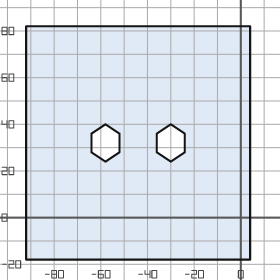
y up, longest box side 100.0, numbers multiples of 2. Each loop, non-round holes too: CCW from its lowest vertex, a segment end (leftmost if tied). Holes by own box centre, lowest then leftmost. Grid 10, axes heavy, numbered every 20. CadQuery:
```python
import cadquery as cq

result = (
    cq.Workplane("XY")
    .moveTo(-92.0, -18.0)
    .lineTo(4.0, -18.0)
    .lineTo(4.0, 82.0)
    .lineTo(-92.0, 82.0)
    .close()
    .moveTo(-58.0, 24.0)
    .lineTo(-52.0, 28.0)
    .lineTo(-52.0, 36.0)
    .lineTo(-58.0, 40.0)
    .lineTo(-64.0, 36.0)
    .lineTo(-64.0, 28.0)
    .close()
    .moveTo(-30.0, 24.0)
    .lineTo(-24.0, 28.0)
    .lineTo(-24.0, 36.0)
    .lineTo(-30.0, 40.0)
    .lineTo(-36.0, 36.0)
    .lineTo(-36.0, 28.0)
    .close()
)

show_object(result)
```